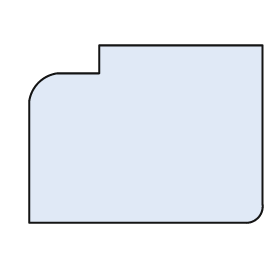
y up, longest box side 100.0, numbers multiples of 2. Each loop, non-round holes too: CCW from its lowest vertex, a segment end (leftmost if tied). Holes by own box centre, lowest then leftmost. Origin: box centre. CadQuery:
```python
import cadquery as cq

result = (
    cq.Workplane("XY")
    .moveTo(-50.0, -38.0)
    .lineTo(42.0, -38.0)
    .threePointArc((48.0, -36.0), (50.0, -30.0))
    .lineTo(50.0, 38.0)
    .lineTo(-20.0, 38.0)
    .lineTo(-20.0, 26.0)
    .lineTo(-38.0, 26.0)
    .threePointArc((-46.0, 22.0), (-50.0, 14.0))
    .close()
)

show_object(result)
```